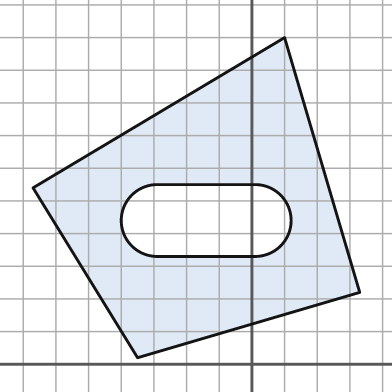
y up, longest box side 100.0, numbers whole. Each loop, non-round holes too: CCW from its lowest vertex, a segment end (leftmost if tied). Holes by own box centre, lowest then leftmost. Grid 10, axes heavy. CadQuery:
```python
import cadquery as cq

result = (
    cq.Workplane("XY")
    .moveTo(-35.0, 2.0)
    .lineTo(33.0, 22.0)
    .lineTo(10.0, 100.0)
    .lineTo(-67.0, 54.0)
    .close()
    .moveTo(-29.0, 33.0)
    .lineTo(1.0, 33.0)
    .threePointArc((12.0, 44.0), (1.0, 55.0))
    .lineTo(-29.0, 55.0)
    .threePointArc((-40.0, 44.0), (-29.0, 33.0))
    .close()
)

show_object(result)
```